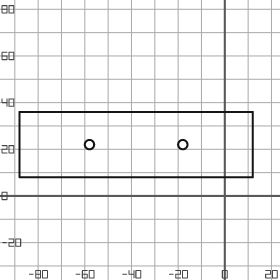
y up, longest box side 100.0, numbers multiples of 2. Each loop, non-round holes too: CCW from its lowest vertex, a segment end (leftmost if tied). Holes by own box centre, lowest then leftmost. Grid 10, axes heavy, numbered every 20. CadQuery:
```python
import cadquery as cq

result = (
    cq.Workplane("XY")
    .moveTo(-88.0, 8.0)
    .lineTo(12.0, 8.0)
    .lineTo(12.0, 36.0)
    .lineTo(-88.0, 36.0)
    .close()
    .moveTo(-58.0, 22.0)
    .circle(2.0)
    .moveTo(-18.0, 22.0)
    .circle(2.0)
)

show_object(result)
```